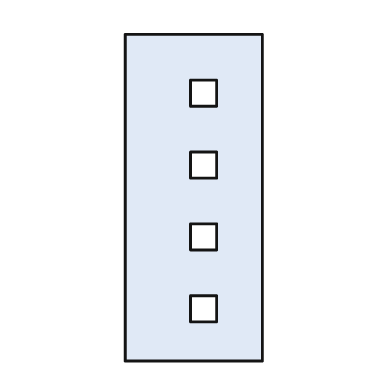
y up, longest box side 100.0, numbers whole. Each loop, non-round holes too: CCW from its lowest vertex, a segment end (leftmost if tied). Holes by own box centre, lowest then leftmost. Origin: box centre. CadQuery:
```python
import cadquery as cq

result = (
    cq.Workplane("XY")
    .moveTo(-21.0, -50.0)
    .lineTo(21.0, -50.0)
    .lineTo(21.0, 50.0)
    .lineTo(-21.0, 50.0)
    .close()
    .moveTo(-1.0, -38.0)
    .lineTo(7.0, -38.0)
    .lineTo(7.0, -30.0)
    .lineTo(-1.0, -30.0)
    .close()
    .moveTo(-1.0, -16.0)
    .lineTo(7.0, -16.0)
    .lineTo(7.0, -8.0)
    .lineTo(-1.0, -8.0)
    .close()
    .moveTo(-1.0, 6.0)
    .lineTo(7.0, 6.0)
    .lineTo(7.0, 14.0)
    .lineTo(-1.0, 14.0)
    .close()
    .moveTo(-1.0, 28.0)
    .lineTo(7.0, 28.0)
    .lineTo(7.0, 36.0)
    .lineTo(-1.0, 36.0)
    .close()
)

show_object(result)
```